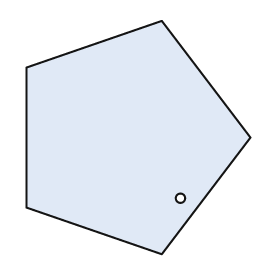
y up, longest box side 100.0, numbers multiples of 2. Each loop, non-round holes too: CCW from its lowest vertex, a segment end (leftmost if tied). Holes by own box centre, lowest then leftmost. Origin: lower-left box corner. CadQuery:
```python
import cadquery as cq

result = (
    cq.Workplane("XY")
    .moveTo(58.0, 0.0)
    .lineTo(96.0, 50.0)
    .lineTo(58.0, 100.0)
    .lineTo(0.0, 80.0)
    .lineTo(0.0, 20.0)
    .close()
    .moveTo(66.0, 24.0)
    .circle(2.0)
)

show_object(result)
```